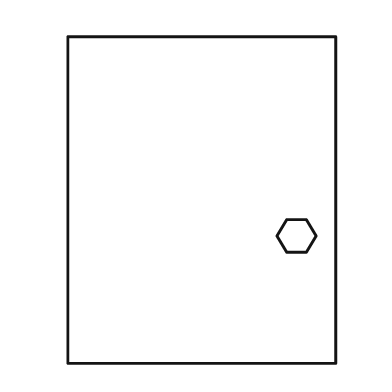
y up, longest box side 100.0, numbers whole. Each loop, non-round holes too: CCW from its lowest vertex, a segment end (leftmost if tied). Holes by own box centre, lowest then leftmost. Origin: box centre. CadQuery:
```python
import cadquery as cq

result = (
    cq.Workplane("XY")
    .moveTo(-41.0, -50.0)
    .lineTo(41.0, -50.0)
    .lineTo(41.0, 50.0)
    .lineTo(-41.0, 50.0)
    .close()
    .moveTo(26.0, -16.0)
    .lineTo(32.0, -16.0)
    .lineTo(35.0, -11.0)
    .lineTo(32.0, -6.0)
    .lineTo(26.0, -6.0)
    .lineTo(23.0, -11.0)
    .close()
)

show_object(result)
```